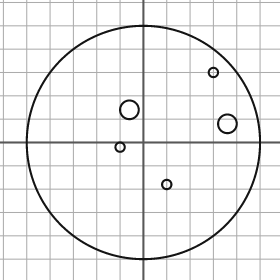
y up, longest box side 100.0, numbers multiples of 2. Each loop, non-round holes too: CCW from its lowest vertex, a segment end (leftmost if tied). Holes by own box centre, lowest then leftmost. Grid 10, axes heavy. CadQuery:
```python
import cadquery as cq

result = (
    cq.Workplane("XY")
    .moveTo(0.0, 0.0)
    .circle(50.0)
    .moveTo(10.0, -18.0)
    .circle(2.0)
    .moveTo(-10.0, -2.0)
    .circle(2.0)
    .moveTo(36.0, 8.0)
    .circle(4.0)
    .moveTo(-6.0, 14.0)
    .circle(4.0)
    .moveTo(30.0, 30.0)
    .circle(2.0)
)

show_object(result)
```